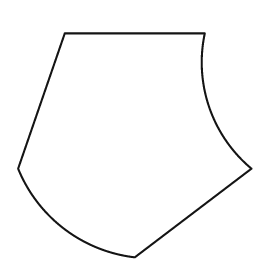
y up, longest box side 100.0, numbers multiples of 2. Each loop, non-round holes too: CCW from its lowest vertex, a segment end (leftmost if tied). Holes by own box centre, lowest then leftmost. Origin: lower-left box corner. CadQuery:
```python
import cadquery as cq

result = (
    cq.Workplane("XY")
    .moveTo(50.0, 0.0)
    .lineTo(100.0, 38.0)
    .threePointArc((82.0, 64.0), (80.0, 96.0))
    .lineTo(20.0, 96.0)
    .lineTo(0.0, 38.0)
    .threePointArc((20.0, 12.0), (50.0, 0.0))
    .close()
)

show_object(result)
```